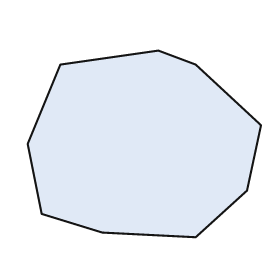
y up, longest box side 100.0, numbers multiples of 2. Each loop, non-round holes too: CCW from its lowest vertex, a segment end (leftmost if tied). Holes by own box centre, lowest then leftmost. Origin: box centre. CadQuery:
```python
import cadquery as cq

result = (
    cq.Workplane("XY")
    .moveTo(22.0, -40.0)
    .lineTo(44.0, -20.0)
    .lineTo(50.0, 8.0)
    .lineTo(22.0, 34.0)
    .lineTo(6.0, 40.0)
    .lineTo(-36.0, 34.0)
    .lineTo(-50.0, 0.0)
    .lineTo(-44.0, -30.0)
    .lineTo(-18.0, -38.0)
    .close()
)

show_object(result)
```